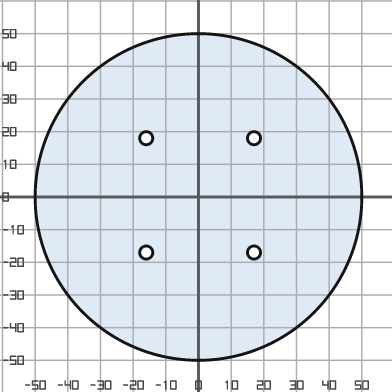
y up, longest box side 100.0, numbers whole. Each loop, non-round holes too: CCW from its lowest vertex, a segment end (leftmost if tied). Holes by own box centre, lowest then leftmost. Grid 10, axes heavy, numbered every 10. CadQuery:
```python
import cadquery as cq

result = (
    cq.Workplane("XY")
    .moveTo(0.0, 0.0)
    .circle(50.0)
    .moveTo(-16.0, -17.0)
    .circle(2.0)
    .moveTo(17.0, -17.0)
    .circle(2.0)
    .moveTo(-16.0, 18.0)
    .circle(2.0)
    .moveTo(17.0, 18.0)
    .circle(2.0)
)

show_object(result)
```